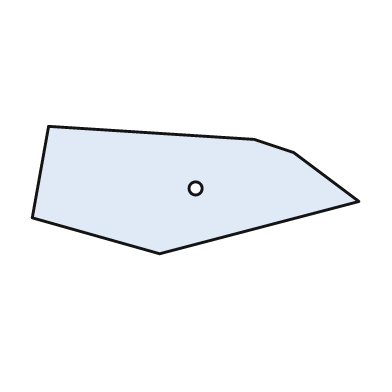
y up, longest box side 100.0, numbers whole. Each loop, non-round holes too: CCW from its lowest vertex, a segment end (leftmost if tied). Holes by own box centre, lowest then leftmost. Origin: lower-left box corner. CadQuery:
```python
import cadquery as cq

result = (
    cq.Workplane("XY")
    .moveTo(39.0, 0.0)
    .lineTo(100.0, 16.0)
    .lineTo(80.0, 31.0)
    .lineTo(68.0, 35.0)
    .lineTo(5.0, 39.0)
    .lineTo(0.0, 11.0)
    .close()
    .moveTo(50.0, 20.0)
    .circle(2.0)
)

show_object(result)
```